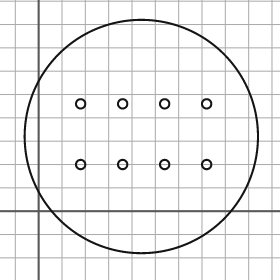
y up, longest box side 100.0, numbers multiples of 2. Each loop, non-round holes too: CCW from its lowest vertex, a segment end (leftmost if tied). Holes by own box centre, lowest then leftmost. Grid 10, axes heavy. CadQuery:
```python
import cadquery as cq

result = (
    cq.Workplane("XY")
    .moveTo(44.0, 32.0)
    .circle(50.0)
    .moveTo(18.0, 20.0)
    .circle(2.0)
    .moveTo(36.0, 20.0)
    .circle(2.0)
    .moveTo(54.0, 20.0)
    .circle(2.0)
    .moveTo(72.0, 20.0)
    .circle(2.0)
    .moveTo(18.0, 46.0)
    .circle(2.0)
    .moveTo(36.0, 46.0)
    .circle(2.0)
    .moveTo(54.0, 46.0)
    .circle(2.0)
    .moveTo(72.0, 46.0)
    .circle(2.0)
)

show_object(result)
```